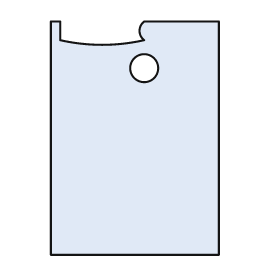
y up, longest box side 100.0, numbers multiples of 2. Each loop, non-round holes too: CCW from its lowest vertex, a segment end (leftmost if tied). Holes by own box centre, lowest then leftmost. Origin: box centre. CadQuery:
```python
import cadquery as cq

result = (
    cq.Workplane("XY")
    .moveTo(-36.0, -50.0)
    .lineTo(36.0, -50.0)
    .lineTo(36.0, 50.0)
    .lineTo(4.0, 50.0)
    .threePointArc((2.0, 46.0), (4.0, 42.0))
    .threePointArc((-14.0, 40.0), (-32.0, 42.0))
    .lineTo(-32.0, 50.0)
    .lineTo(-36.0, 50.0)
    .close()
    .moveTo(4.0, 30.0)
    .circle(6.0)
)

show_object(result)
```